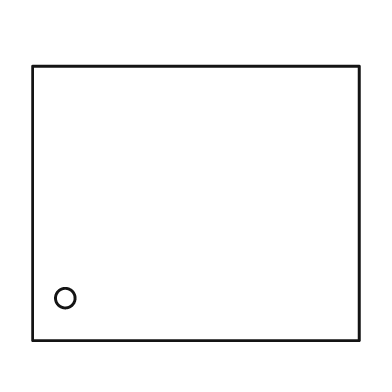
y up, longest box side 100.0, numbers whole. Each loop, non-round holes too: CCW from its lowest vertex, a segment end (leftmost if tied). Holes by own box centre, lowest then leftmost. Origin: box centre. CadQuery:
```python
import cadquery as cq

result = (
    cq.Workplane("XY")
    .moveTo(-50.0, -42.0)
    .lineTo(50.0, -42.0)
    .lineTo(50.0, 42.0)
    .lineTo(-50.0, 42.0)
    .close()
    .moveTo(-40.0, -29.0)
    .circle(3.0)
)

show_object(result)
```